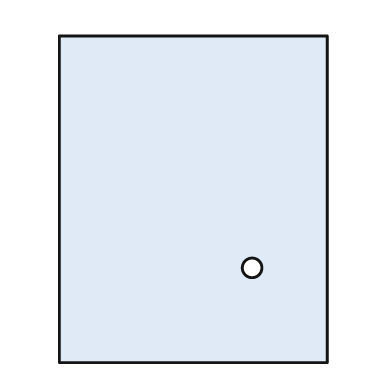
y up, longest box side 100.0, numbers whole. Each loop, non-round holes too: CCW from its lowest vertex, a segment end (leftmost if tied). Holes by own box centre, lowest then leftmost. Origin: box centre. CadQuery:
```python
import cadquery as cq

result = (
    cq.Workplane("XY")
    .moveTo(-41.0, -50.0)
    .lineTo(41.0, -50.0)
    .lineTo(41.0, 50.0)
    .lineTo(-41.0, 50.0)
    .close()
    .moveTo(18.0, -21.0)
    .circle(3.0)
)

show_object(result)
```